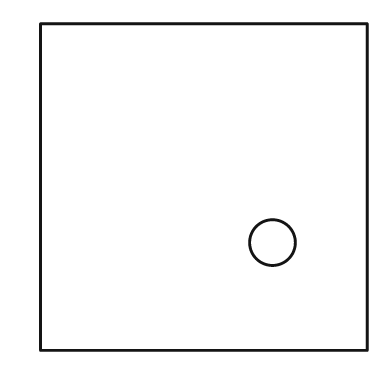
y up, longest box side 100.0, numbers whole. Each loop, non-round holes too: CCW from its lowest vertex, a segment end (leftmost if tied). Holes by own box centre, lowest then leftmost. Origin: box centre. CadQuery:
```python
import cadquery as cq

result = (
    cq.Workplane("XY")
    .moveTo(-50.0, -50.0)
    .lineTo(50.0, -50.0)
    .lineTo(50.0, 50.0)
    .lineTo(-50.0, 50.0)
    .close()
    .moveTo(21.0, -17.0)
    .circle(7.0)
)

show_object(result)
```